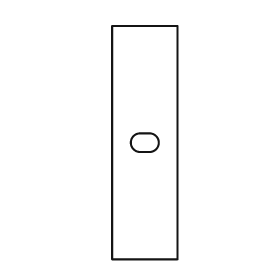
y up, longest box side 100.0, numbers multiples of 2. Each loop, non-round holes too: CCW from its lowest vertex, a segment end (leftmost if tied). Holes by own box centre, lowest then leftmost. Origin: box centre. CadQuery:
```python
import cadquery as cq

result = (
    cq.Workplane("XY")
    .moveTo(-14.0, -50.0)
    .lineTo(14.0, -50.0)
    .lineTo(14.0, 50.0)
    .lineTo(-14.0, 50.0)
    .close()
    .moveTo(-2.0, -4.0)
    .lineTo(2.0, -4.0)
    .threePointArc((6.0, 0.0), (2.0, 4.0))
    .lineTo(-2.0, 4.0)
    .threePointArc((-6.0, 0.0), (-2.0, -4.0))
    .close()
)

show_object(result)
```